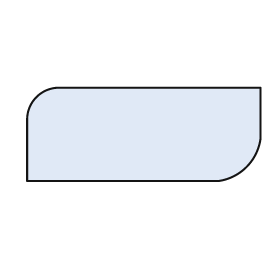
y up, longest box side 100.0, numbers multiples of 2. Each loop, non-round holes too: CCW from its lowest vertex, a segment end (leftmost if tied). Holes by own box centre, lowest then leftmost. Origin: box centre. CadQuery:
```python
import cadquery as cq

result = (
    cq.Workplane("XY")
    .moveTo(-50.0, -20.0)
    .lineTo(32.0, -20.0)
    .threePointArc((44.0, -14.0), (50.0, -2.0))
    .lineTo(50.0, 20.0)
    .lineTo(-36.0, 20.0)
    .threePointArc((-46.0, 16.0), (-50.0, 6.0))
    .close()
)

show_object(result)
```